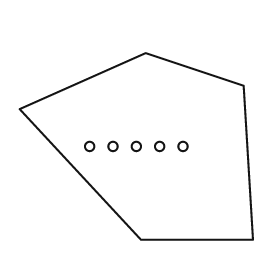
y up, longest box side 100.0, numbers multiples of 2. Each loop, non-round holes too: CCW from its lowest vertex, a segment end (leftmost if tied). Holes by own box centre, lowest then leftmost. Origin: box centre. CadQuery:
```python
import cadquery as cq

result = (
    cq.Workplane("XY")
    .moveTo(2.0, -40.0)
    .lineTo(50.0, -40.0)
    .lineTo(46.0, 26.0)
    .lineTo(4.0, 40.0)
    .lineTo(-50.0, 16.0)
    .close()
    .moveTo(-20.0, 0.0)
    .circle(2.0)
    .moveTo(-10.0, 0.0)
    .circle(2.0)
    .moveTo(0.0, 0.0)
    .circle(2.0)
    .moveTo(10.0, 0.0)
    .circle(2.0)
    .moveTo(20.0, 0.0)
    .circle(2.0)
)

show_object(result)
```